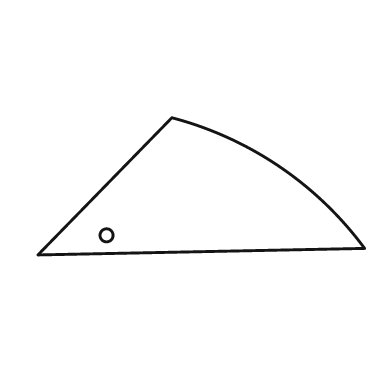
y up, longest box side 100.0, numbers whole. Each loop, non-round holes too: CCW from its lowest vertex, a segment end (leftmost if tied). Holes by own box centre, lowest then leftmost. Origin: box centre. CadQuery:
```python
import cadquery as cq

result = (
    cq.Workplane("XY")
    .moveTo(-50.0, -21.0)
    .lineTo(50.0, -19.0)
    .threePointArc((24.0, 6.0), (-9.0, 21.0))
    .close()
    .moveTo(-29.0, -15.0)
    .circle(2.0)
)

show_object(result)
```